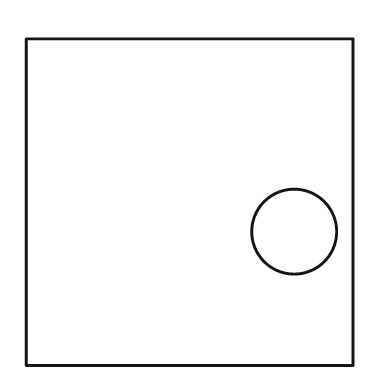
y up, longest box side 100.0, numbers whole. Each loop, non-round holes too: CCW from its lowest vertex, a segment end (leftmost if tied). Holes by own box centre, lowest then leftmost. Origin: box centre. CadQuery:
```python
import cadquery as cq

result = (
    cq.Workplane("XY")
    .moveTo(-50.0, -50.0)
    .lineTo(50.0, -50.0)
    .lineTo(50.0, 50.0)
    .lineTo(-50.0, 50.0)
    .close()
    .moveTo(32.0, -9.0)
    .circle(13.0)
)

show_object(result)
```